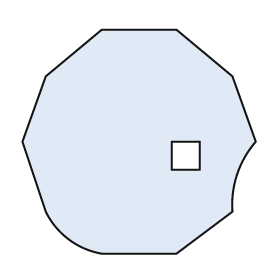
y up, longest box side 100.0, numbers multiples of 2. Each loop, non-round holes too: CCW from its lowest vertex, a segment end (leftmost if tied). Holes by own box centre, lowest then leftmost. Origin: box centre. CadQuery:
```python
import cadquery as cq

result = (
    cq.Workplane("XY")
    .moveTo(-16.0, -48.0)
    .lineTo(16.0, -48.0)
    .lineTo(40.0, -30.0)
    .threePointArc((42.0, -14.0), (50.0, 0.0))
    .lineTo(40.0, 28.0)
    .lineTo(16.0, 48.0)
    .lineTo(-16.0, 48.0)
    .lineTo(-40.0, 28.0)
    .lineTo(-50.0, 0.0)
    .lineTo(-40.0, -30.0)
    .threePointArc((-30.0, -42.0), (-16.0, -48.0))
    .close()
    .moveTo(14.0, -12.0)
    .lineTo(26.0, -12.0)
    .lineTo(26.0, 0.0)
    .lineTo(14.0, 0.0)
    .close()
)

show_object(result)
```